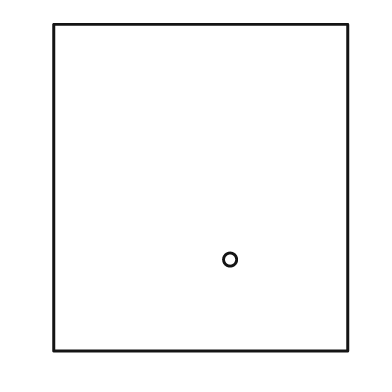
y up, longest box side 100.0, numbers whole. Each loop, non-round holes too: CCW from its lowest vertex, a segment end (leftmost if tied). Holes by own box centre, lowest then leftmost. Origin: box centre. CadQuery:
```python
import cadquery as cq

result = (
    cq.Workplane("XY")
    .moveTo(-45.0, -50.0)
    .lineTo(45.0, -50.0)
    .lineTo(45.0, 50.0)
    .lineTo(-45.0, 50.0)
    .close()
    .moveTo(9.0, -22.0)
    .circle(2.0)
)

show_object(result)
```